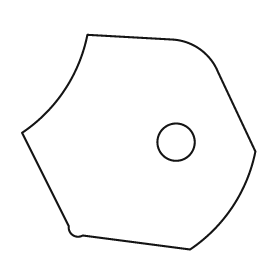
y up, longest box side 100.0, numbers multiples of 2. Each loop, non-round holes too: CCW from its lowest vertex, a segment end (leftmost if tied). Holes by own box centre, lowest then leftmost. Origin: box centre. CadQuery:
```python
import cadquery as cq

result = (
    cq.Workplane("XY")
    .moveTo(22.0, -46.0)
    .threePointArc((40.0, -28.0), (50.0, -4.0))
    .lineTo(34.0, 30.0)
    .threePointArc((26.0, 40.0), (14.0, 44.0))
    .lineTo(-22.0, 46.0)
    .threePointArc((-32.0, 22.0), (-50.0, 4.0))
    .lineTo(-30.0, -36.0)
    .threePointArc((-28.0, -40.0), (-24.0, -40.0))
    .close()
    .moveTo(16.0, 0.0)
    .circle(8.0)
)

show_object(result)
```